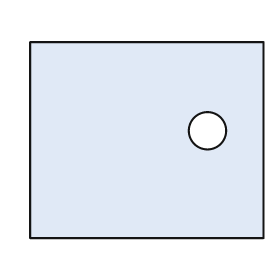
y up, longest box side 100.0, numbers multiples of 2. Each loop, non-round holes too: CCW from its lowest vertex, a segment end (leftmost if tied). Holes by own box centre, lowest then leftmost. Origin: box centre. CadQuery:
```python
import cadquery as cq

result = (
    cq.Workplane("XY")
    .moveTo(-50.0, -42.0)
    .lineTo(50.0, -42.0)
    .lineTo(50.0, 42.0)
    .lineTo(-50.0, 42.0)
    .close()
    .moveTo(26.0, 4.0)
    .circle(8.0)
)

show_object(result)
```